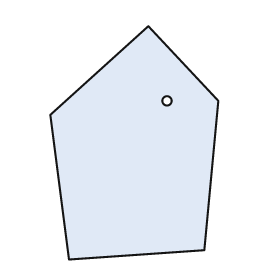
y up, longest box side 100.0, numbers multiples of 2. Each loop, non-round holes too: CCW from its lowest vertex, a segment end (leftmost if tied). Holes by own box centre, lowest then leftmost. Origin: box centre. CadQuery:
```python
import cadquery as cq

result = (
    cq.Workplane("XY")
    .moveTo(-28.0, -50.0)
    .lineTo(30.0, -46.0)
    .lineTo(36.0, 18.0)
    .lineTo(6.0, 50.0)
    .lineTo(-36.0, 12.0)
    .close()
    .moveTo(14.0, 18.0)
    .circle(2.0)
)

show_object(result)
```